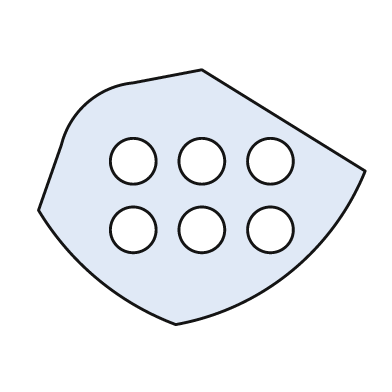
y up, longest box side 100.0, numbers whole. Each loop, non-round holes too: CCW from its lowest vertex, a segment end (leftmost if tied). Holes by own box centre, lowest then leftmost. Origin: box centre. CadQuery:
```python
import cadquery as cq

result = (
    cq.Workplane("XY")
    .moveTo(-8.0, -39.0)
    .threePointArc((27.0, -23.0), (50.0, 8.0))
    .lineTo(0.0, 39.0)
    .lineTo(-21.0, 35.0)
    .threePointArc((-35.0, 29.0), (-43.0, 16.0))
    .lineTo(-50.0, -4.0)
    .threePointArc((-32.0, -25.0), (-8.0, -39.0))
    .close()
    .moveTo(-21.0, -10.0)
    .circle(7.0)
    .moveTo(0.0, -10.0)
    .circle(7.0)
    .moveTo(21.0, -10.0)
    .circle(7.0)
    .moveTo(-21.0, 11.0)
    .circle(7.0)
    .moveTo(0.0, 11.0)
    .circle(7.0)
    .moveTo(21.0, 11.0)
    .circle(7.0)
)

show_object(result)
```